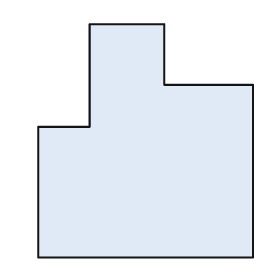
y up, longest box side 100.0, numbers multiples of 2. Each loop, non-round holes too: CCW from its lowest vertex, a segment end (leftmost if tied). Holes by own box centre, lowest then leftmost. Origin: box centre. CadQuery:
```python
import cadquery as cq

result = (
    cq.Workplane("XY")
    .moveTo(-46.0, -50.0)
    .lineTo(46.0, -50.0)
    .lineTo(46.0, 24.0)
    .lineTo(8.0, 24.0)
    .lineTo(8.0, 50.0)
    .lineTo(-24.0, 50.0)
    .lineTo(-24.0, 6.0)
    .lineTo(-46.0, 6.0)
    .close()
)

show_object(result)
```